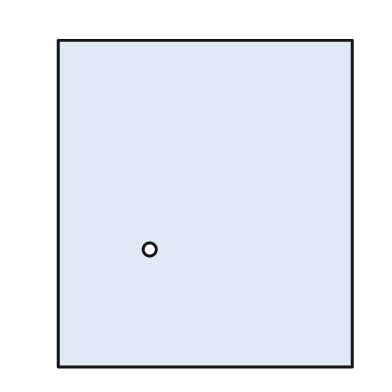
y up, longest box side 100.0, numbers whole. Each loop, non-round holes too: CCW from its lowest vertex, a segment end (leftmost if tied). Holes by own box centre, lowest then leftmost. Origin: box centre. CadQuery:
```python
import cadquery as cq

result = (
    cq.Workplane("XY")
    .moveTo(-45.0, -50.0)
    .lineTo(45.0, -50.0)
    .lineTo(45.0, 50.0)
    .lineTo(-45.0, 50.0)
    .close()
    .moveTo(-17.0, -14.0)
    .circle(2.0)
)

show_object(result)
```